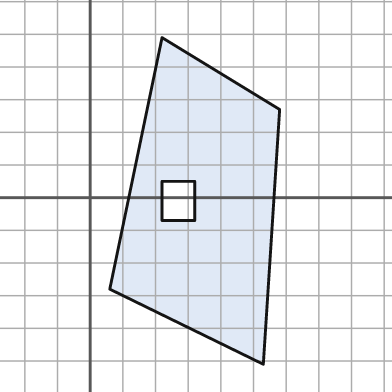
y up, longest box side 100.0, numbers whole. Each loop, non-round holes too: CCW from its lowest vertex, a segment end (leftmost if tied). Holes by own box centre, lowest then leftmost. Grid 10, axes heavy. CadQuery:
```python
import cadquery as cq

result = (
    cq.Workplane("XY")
    .moveTo(53.0, -51.0)
    .lineTo(58.0, 27.0)
    .lineTo(22.0, 49.0)
    .lineTo(6.0, -28.0)
    .close()
    .moveTo(22.0, -7.0)
    .lineTo(32.0, -7.0)
    .lineTo(32.0, 5.0)
    .lineTo(22.0, 5.0)
    .close()
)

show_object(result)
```